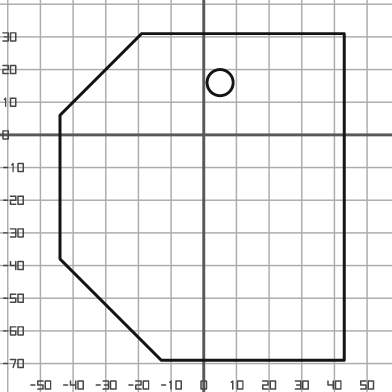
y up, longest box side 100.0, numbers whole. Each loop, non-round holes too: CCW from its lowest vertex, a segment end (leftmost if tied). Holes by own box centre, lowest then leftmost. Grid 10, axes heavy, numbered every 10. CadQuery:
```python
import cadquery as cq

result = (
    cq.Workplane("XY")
    .moveTo(-13.0, -69.0)
    .lineTo(43.0, -69.0)
    .lineTo(43.0, 31.0)
    .lineTo(-19.0, 31.0)
    .lineTo(-44.0, 6.0)
    .lineTo(-44.0, -38.0)
    .close()
    .moveTo(5.0, 16.0)
    .circle(4.0)
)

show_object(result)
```